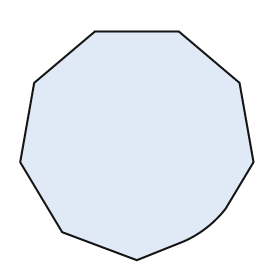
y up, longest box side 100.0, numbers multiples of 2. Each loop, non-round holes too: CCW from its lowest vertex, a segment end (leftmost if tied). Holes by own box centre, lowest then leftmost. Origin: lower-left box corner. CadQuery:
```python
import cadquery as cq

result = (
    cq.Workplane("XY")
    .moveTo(50.0, 0.0)
    .lineTo(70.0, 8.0)
    .threePointArc((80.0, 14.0), (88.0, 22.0))
    .lineTo(100.0, 42.0)
    .lineTo(94.0, 76.0)
    .lineTo(68.0, 98.0)
    .lineTo(32.0, 98.0)
    .lineTo(6.0, 76.0)
    .lineTo(0.0, 42.0)
    .lineTo(18.0, 12.0)
    .close()
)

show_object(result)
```